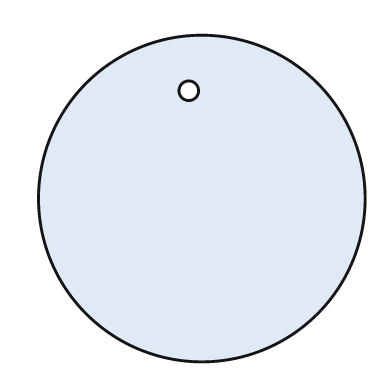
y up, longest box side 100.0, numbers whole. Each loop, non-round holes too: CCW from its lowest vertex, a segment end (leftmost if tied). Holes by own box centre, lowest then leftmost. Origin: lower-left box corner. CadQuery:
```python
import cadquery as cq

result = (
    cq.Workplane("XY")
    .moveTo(50.0, 50.0)
    .circle(50.0)
    .moveTo(46.0, 83.0)
    .circle(3.0)
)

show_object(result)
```